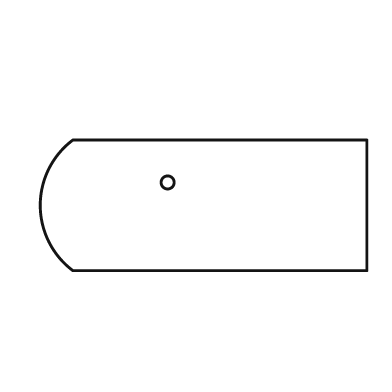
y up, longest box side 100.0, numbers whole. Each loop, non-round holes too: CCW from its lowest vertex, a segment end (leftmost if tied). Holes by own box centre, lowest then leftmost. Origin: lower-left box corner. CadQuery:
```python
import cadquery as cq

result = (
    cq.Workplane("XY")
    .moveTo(10.0, 0.0)
    .lineTo(100.0, 0.0)
    .lineTo(100.0, 40.0)
    .lineTo(10.0, 40.0)
    .threePointArc((0.0, 20.0), (10.0, 0.0))
    .close()
    .moveTo(39.0, 27.0)
    .circle(2.0)
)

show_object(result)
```